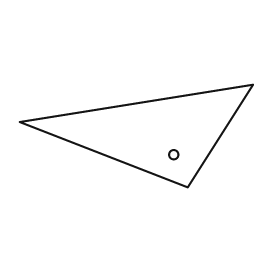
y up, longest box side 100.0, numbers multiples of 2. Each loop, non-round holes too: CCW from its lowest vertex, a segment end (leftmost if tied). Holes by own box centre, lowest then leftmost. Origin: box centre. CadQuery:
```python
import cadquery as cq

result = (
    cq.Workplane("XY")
    .moveTo(22.0, -22.0)
    .lineTo(50.0, 22.0)
    .lineTo(-50.0, 6.0)
    .close()
    .moveTo(16.0, -8.0)
    .circle(2.0)
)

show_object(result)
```